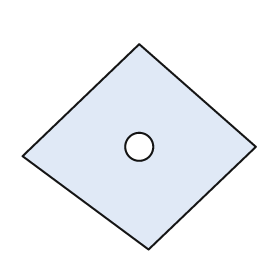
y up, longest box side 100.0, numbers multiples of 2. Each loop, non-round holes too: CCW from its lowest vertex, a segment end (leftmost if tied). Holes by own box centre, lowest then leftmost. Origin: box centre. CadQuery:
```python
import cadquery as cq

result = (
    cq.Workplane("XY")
    .moveTo(4.0, -44.0)
    .lineTo(50.0, 0.0)
    .lineTo(0.0, 44.0)
    .lineTo(-50.0, -4.0)
    .close()
    .moveTo(0.0, 0.0)
    .circle(6.0)
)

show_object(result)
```